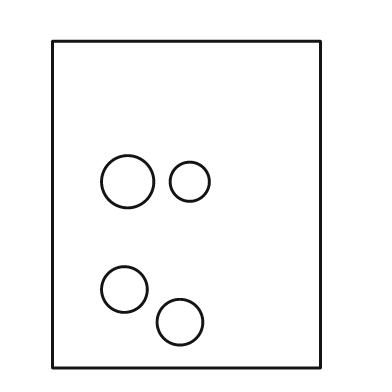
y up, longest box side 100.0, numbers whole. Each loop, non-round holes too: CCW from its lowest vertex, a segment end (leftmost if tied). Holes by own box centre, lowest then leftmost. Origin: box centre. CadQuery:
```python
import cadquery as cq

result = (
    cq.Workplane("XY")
    .moveTo(-41.0, -50.0)
    .lineTo(41.0, -50.0)
    .lineTo(41.0, 50.0)
    .lineTo(-41.0, 50.0)
    .close()
    .moveTo(-2.0, -36.0)
    .circle(7.0)
    .moveTo(-19.0, -26.0)
    .circle(7.0)
    .moveTo(-18.0, 7.0)
    .circle(8.0)
    .moveTo(1.0, 7.0)
    .circle(6.0)
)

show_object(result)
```